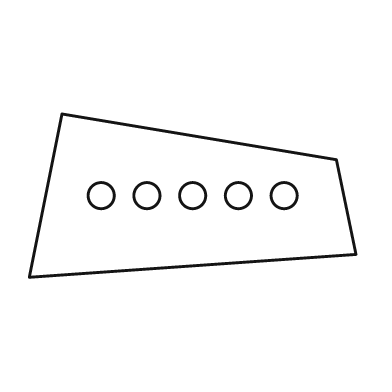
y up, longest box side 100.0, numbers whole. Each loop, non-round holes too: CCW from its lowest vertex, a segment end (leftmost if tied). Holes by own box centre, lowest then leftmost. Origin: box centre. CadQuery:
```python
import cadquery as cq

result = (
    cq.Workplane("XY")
    .moveTo(-50.0, -25.0)
    .lineTo(50.0, -18.0)
    .lineTo(44.0, 11.0)
    .lineTo(-40.0, 25.0)
    .close()
    .moveTo(-28.0, 0.0)
    .circle(4.0)
    .moveTo(-14.0, 0.0)
    .circle(4.0)
    .moveTo(0.0, 0.0)
    .circle(4.0)
    .moveTo(14.0, 0.0)
    .circle(4.0)
    .moveTo(28.0, 0.0)
    .circle(4.0)
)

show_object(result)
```